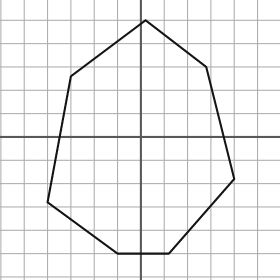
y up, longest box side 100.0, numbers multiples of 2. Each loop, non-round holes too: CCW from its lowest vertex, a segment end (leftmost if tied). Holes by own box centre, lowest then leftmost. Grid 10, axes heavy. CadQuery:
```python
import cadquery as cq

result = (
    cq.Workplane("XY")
    .moveTo(-10.0, -50.0)
    .lineTo(12.0, -50.0)
    .lineTo(40.0, -18.0)
    .lineTo(28.0, 30.0)
    .lineTo(2.0, 50.0)
    .lineTo(-30.0, 26.0)
    .lineTo(-40.0, -28.0)
    .close()
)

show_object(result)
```